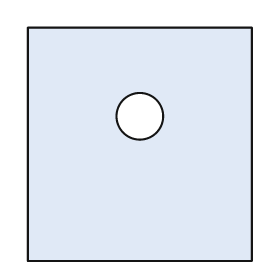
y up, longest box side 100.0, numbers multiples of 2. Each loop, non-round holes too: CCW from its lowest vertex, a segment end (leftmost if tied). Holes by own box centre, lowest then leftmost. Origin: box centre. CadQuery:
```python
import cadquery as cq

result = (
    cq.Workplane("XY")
    .moveTo(-48.0, -50.0)
    .lineTo(48.0, -50.0)
    .lineTo(48.0, 50.0)
    .lineTo(-48.0, 50.0)
    .close()
    .moveTo(0.0, 12.0)
    .circle(10.0)
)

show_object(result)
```